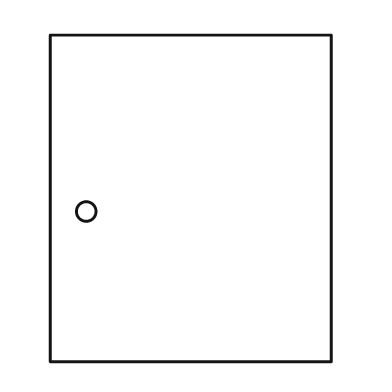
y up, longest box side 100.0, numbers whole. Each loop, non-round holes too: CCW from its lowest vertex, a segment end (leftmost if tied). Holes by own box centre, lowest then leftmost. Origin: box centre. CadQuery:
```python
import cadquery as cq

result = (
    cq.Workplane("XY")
    .moveTo(-43.0, -50.0)
    .lineTo(43.0, -50.0)
    .lineTo(43.0, 50.0)
    .lineTo(-43.0, 50.0)
    .close()
    .moveTo(-32.0, -4.0)
    .circle(3.0)
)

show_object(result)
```